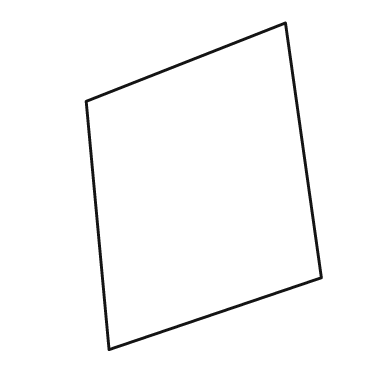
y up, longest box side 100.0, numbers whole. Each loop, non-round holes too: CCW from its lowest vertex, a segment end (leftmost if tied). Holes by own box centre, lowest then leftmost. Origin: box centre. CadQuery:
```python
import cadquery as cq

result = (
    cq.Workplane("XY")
    .moveTo(-29.0, -50.0)
    .lineTo(36.0, -28.0)
    .lineTo(25.0, 50.0)
    .lineTo(-36.0, 26.0)
    .close()
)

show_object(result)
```